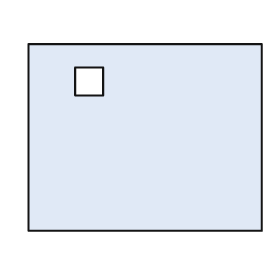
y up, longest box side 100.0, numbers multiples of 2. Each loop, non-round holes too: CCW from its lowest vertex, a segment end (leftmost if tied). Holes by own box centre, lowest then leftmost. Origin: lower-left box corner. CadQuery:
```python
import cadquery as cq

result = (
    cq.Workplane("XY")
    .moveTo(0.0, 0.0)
    .lineTo(100.0, 0.0)
    .lineTo(100.0, 80.0)
    .lineTo(0.0, 80.0)
    .close()
    .moveTo(20.0, 58.0)
    .lineTo(32.0, 58.0)
    .lineTo(32.0, 70.0)
    .lineTo(20.0, 70.0)
    .close()
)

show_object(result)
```